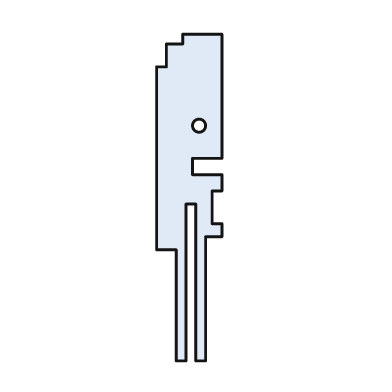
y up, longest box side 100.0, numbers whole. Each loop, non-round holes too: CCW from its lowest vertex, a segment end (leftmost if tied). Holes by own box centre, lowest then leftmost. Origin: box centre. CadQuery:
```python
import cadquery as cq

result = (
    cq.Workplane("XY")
    .moveTo(-4.0, -50.0)
    .lineTo(-1.0, -50.0)
    .lineTo(-1.0, -2.0)
    .lineTo(2.0, -2.0)
    .lineTo(2.0, -50.0)
    .lineTo(5.0, -50.0)
    .lineTo(5.0, -12.0)
    .lineTo(10.0, -12.0)
    .lineTo(10.0, -8.0)
    .lineTo(7.0, -8.0)
    .lineTo(7.0, 2.0)
    .lineTo(10.0, 2.0)
    .lineTo(10.0, 7.0)
    .lineTo(1.0, 7.0)
    .lineTo(1.0, 12.0)
    .lineTo(10.0, 12.0)
    .lineTo(10.0, 50.0)
    .lineTo(-2.0, 50.0)
    .lineTo(-2.0, 47.0)
    .lineTo(-7.0, 47.0)
    .lineTo(-7.0, 40.0)
    .lineTo(-10.0, 40.0)
    .lineTo(-10.0, -16.0)
    .lineTo(-4.0, -16.0)
    .close()
    .moveTo(3.0, 22.0)
    .circle(2.0)
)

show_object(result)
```